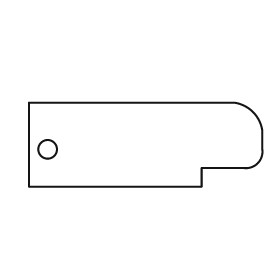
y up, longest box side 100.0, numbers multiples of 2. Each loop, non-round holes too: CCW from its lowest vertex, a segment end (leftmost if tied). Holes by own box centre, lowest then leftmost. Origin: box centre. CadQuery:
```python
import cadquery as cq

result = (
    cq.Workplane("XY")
    .moveTo(-50.0, -18.0)
    .lineTo(24.0, -18.0)
    .lineTo(24.0, -10.0)
    .lineTo(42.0, -10.0)
    .threePointArc((48.0, -8.0), (50.0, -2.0))
    .lineTo(50.0, 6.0)
    .threePointArc((46.0, 14.0), (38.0, 18.0))
    .lineTo(-50.0, 18.0)
    .close()
    .moveTo(-42.0, -2.0)
    .circle(4.0)
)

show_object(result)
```